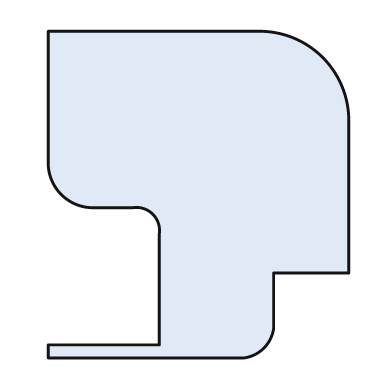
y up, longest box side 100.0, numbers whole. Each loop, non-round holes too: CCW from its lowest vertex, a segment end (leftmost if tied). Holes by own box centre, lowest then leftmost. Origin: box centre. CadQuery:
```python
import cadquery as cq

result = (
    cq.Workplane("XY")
    .moveTo(-46.0, -50.0)
    .lineTo(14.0, -50.0)
    .threePointArc((20.0, -47.0), (23.0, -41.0))
    .lineTo(23.0, -24.0)
    .lineTo(46.0, -24.0)
    .lineTo(46.0, 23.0)
    .threePointArc((38.0, 42.0), (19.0, 50.0))
    .lineTo(-46.0, 50.0)
    .lineTo(-46.0, 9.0)
    .threePointArc((-42.0, 0.0), (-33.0, -4.0))
    .lineTo(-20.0, -4.0)
    .threePointArc((-14.0, -6.0), (-12.0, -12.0))
    .lineTo(-12.0, -46.0)
    .lineTo(-46.0, -46.0)
    .close()
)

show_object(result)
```